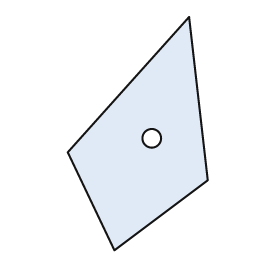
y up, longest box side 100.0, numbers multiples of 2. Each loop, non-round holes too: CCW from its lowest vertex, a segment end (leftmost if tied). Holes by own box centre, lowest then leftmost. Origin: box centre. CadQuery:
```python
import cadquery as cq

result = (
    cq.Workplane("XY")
    .moveTo(-10.0, -50.0)
    .lineTo(30.0, -20.0)
    .lineTo(22.0, 50.0)
    .lineTo(-30.0, -8.0)
    .close()
    .moveTo(6.0, -2.0)
    .circle(4.0)
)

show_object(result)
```